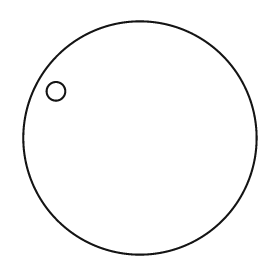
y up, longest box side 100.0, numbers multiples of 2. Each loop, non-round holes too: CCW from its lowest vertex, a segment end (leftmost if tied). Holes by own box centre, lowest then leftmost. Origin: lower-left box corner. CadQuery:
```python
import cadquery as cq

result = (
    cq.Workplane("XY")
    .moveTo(50.0, 50.0)
    .circle(50.0)
    .moveTo(14.0, 70.0)
    .circle(4.0)
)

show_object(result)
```